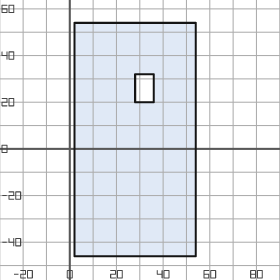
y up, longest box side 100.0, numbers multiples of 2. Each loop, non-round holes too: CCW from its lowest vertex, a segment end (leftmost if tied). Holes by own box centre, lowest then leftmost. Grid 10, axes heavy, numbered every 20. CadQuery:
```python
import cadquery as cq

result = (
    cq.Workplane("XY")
    .moveTo(2.0, -46.0)
    .lineTo(54.0, -46.0)
    .lineTo(54.0, 54.0)
    .lineTo(2.0, 54.0)
    .close()
    .moveTo(28.0, 20.0)
    .lineTo(36.0, 20.0)
    .lineTo(36.0, 32.0)
    .lineTo(28.0, 32.0)
    .close()
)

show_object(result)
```